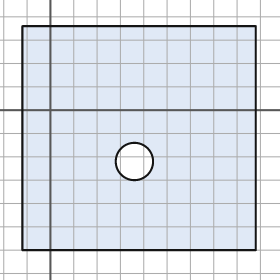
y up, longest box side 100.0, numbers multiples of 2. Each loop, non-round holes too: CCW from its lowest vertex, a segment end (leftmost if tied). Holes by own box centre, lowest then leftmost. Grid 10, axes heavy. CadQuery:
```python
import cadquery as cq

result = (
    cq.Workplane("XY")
    .moveTo(-12.0, -60.0)
    .lineTo(88.0, -60.0)
    .lineTo(88.0, 36.0)
    .lineTo(-12.0, 36.0)
    .close()
    .moveTo(36.0, -22.0)
    .circle(8.0)
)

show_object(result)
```